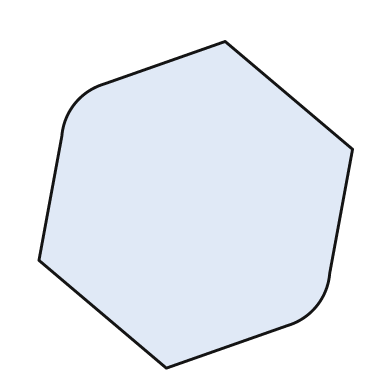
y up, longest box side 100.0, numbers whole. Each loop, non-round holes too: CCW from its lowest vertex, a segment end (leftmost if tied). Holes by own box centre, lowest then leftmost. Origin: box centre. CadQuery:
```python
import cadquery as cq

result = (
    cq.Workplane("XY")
    .moveTo(-9.0, -50.0)
    .lineTo(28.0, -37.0)
    .threePointArc((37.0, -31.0), (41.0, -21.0))
    .lineTo(48.0, 17.0)
    .lineTo(9.0, 50.0)
    .lineTo(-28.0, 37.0)
    .threePointArc((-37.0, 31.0), (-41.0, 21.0))
    .lineTo(-48.0, -17.0)
    .close()
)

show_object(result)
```